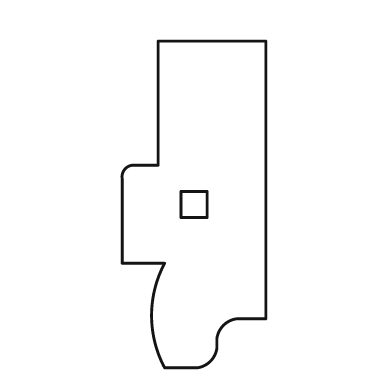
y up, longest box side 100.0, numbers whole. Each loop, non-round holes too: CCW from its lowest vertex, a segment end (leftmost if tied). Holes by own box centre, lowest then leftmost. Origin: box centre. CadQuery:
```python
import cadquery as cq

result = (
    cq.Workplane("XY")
    .moveTo(-9.0, -50.0)
    .lineTo(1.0, -50.0)
    .threePointArc((5.0, -48.0), (7.0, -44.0))
    .lineTo(7.0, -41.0)
    .threePointArc((9.0, -37.0), (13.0, -35.0))
    .lineTo(22.0, -35.0)
    .lineTo(22.0, 50.0)
    .lineTo(-11.0, 50.0)
    .lineTo(-11.0, 12.0)
    .lineTo(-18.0, 12.0)
    .threePointArc((-21.0, 11.0), (-22.0, 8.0))
    .lineTo(-22.0, -18.0)
    .lineTo(-9.0, -18.0)
    .threePointArc((-13.0, -34.0), (-9.0, -50.0))
    .close()
    .moveTo(-4.0, -4.0)
    .lineTo(4.0, -4.0)
    .lineTo(4.0, 4.0)
    .lineTo(-4.0, 4.0)
    .close()
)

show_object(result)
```